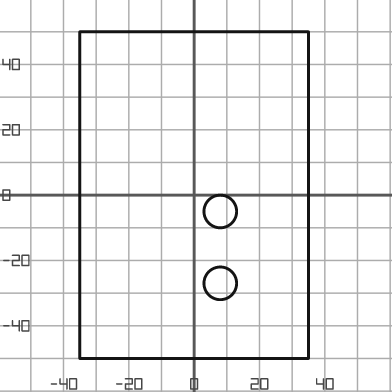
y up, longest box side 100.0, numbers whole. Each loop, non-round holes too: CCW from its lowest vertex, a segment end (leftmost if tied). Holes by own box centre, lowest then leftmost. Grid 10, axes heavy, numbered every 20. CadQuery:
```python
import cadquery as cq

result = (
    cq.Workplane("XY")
    .moveTo(-35.0, -50.0)
    .lineTo(35.0, -50.0)
    .lineTo(35.0, 50.0)
    .lineTo(-35.0, 50.0)
    .close()
    .moveTo(8.0, -27.0)
    .circle(5.0)
    .moveTo(8.0, -5.0)
    .circle(5.0)
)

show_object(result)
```